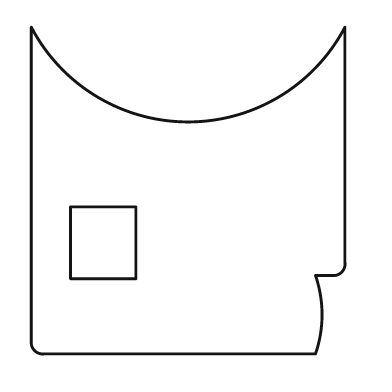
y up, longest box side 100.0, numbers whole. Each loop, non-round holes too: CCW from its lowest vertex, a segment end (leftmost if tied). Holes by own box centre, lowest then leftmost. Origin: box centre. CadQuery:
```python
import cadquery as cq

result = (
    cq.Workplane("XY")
    .moveTo(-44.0, -50.0)
    .lineTo(39.0, -50.0)
    .threePointArc((41.0, -38.0), (39.0, -26.0))
    .lineTo(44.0, -26.0)
    .threePointArc((47.0, -25.0), (48.0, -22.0))
    .lineTo(48.0, 50.0)
    .threePointArc((0.0, 21.0), (-48.0, 50.0))
    .lineTo(-48.0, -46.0)
    .threePointArc((-47.0, -49.0), (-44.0, -50.0))
    .close()
    .moveTo(-36.0, -27.0)
    .lineTo(-16.0, -27.0)
    .lineTo(-16.0, -5.0)
    .lineTo(-36.0, -5.0)
    .close()
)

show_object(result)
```